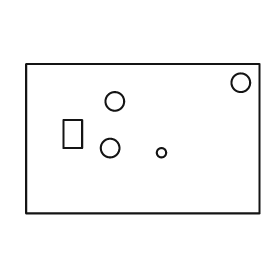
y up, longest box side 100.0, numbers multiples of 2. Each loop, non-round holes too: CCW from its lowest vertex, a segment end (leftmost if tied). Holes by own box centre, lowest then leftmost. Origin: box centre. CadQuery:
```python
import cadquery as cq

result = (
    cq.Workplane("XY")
    .moveTo(-50.0, -32.0)
    .lineTo(50.0, -32.0)
    .lineTo(50.0, 32.0)
    .lineTo(-50.0, 32.0)
    .close()
    .moveTo(8.0, -6.0)
    .circle(2.0)
    .moveTo(-14.0, -4.0)
    .circle(4.0)
    .moveTo(-34.0, -4.0)
    .lineTo(-26.0, -4.0)
    .lineTo(-26.0, 8.0)
    .lineTo(-34.0, 8.0)
    .close()
    .moveTo(-12.0, 16.0)
    .circle(4.0)
    .moveTo(42.0, 24.0)
    .circle(4.0)
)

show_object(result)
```